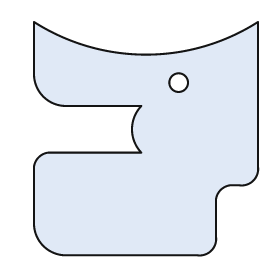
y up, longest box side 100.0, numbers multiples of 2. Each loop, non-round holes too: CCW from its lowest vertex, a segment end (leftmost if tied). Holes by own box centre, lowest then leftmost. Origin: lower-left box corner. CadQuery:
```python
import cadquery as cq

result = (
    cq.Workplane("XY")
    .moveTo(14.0, 0.0)
    .lineTo(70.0, 0.0)
    .threePointArc((76.0, 2.0), (78.0, 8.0))
    .lineTo(78.0, 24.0)
    .threePointArc((80.0, 28.0), (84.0, 30.0))
    .lineTo(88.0, 30.0)
    .threePointArc((94.0, 32.0), (96.0, 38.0))
    .lineTo(96.0, 100.0)
    .threePointArc((48.0, 86.0), (0.0, 100.0))
    .lineTo(0.0, 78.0)
    .threePointArc((4.0, 68.0), (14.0, 64.0))
    .lineTo(46.0, 64.0)
    .threePointArc((42.0, 54.0), (46.0, 44.0))
    .lineTo(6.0, 44.0)
    .threePointArc((2.0, 42.0), (0.0, 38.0))
    .lineTo(0.0, 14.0)
    .threePointArc((4.0, 4.0), (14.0, 0.0))
    .close()
    .moveTo(62.0, 74.0)
    .circle(4.0)
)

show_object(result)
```